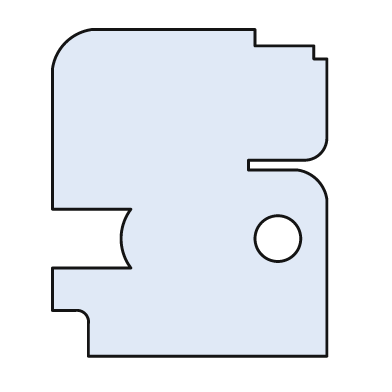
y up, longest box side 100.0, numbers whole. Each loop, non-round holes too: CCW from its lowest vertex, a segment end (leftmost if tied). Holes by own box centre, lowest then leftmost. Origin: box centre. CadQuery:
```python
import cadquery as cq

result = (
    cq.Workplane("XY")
    .moveTo(-31.0, -50.0)
    .lineTo(42.0, -50.0)
    .lineTo(42.0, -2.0)
    .threePointArc((39.0, 4.0), (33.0, 7.0))
    .lineTo(18.0, 7.0)
    .lineTo(18.0, 10.0)
    .lineTo(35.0, 10.0)
    .threePointArc((40.0, 12.0), (42.0, 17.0))
    .lineTo(42.0, 41.0)
    .lineTo(38.0, 41.0)
    .lineTo(38.0, 45.0)
    .lineTo(20.0, 45.0)
    .lineTo(20.0, 50.0)
    .lineTo(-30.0, 50.0)
    .threePointArc((-38.0, 46.0), (-42.0, 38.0))
    .lineTo(-42.0, -5.0)
    .lineTo(-18.0, -5.0)
    .threePointArc((-21.0, -14.0), (-18.0, -23.0))
    .lineTo(-42.0, -23.0)
    .lineTo(-42.0, -36.0)
    .lineTo(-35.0, -36.0)
    .threePointArc((-32.0, -37.0), (-31.0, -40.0))
    .close()
    .moveTo(27.0, -14.0)
    .circle(7.0)
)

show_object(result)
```